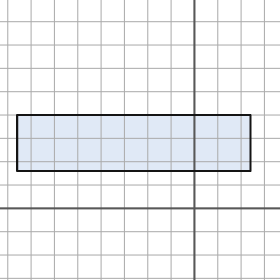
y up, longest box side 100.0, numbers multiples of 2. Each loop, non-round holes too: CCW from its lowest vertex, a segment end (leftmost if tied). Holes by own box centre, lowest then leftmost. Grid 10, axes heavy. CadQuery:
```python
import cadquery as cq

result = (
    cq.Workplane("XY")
    .moveTo(-76.0, 16.0)
    .lineTo(24.0, 16.0)
    .lineTo(24.0, 40.0)
    .lineTo(-76.0, 40.0)
    .close()
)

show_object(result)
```